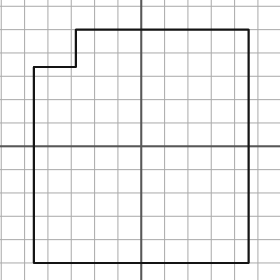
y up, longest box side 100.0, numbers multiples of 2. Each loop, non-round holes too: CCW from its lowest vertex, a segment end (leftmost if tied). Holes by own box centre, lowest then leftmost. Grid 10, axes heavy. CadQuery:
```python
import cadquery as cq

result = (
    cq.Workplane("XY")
    .moveTo(-46.0, -50.0)
    .lineTo(46.0, -50.0)
    .lineTo(46.0, 50.0)
    .lineTo(-28.0, 50.0)
    .lineTo(-28.0, 34.0)
    .lineTo(-46.0, 34.0)
    .close()
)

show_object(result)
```